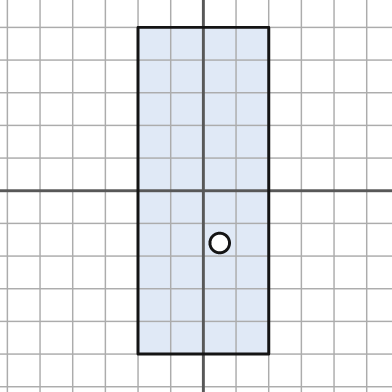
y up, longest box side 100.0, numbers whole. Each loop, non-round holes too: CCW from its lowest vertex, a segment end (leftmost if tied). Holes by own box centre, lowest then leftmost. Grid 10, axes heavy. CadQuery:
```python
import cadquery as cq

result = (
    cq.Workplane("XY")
    .moveTo(-20.0, -50.0)
    .lineTo(20.0, -50.0)
    .lineTo(20.0, 50.0)
    .lineTo(-20.0, 50.0)
    .close()
    .moveTo(5.0, -16.0)
    .circle(3.0)
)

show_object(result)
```